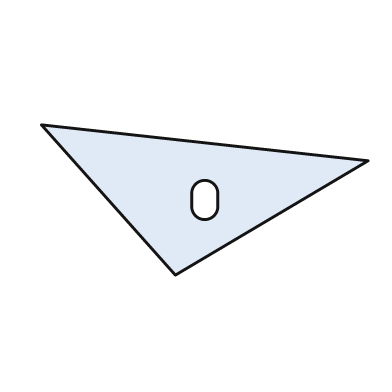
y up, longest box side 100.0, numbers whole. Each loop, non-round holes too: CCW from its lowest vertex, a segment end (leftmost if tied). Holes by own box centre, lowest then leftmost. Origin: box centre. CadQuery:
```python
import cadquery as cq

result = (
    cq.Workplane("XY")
    .moveTo(-9.0, -23.0)
    .lineTo(50.0, 12.0)
    .lineTo(-50.0, 23.0)
    .close()
    .moveTo(-4.0, -2.0)
    .threePointArc((0.0, -6.0), (4.0, -2.0))
    .lineTo(4.0, 2.0)
    .threePointArc((0.0, 6.0), (-4.0, 2.0))
    .close()
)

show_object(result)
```